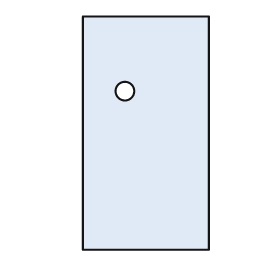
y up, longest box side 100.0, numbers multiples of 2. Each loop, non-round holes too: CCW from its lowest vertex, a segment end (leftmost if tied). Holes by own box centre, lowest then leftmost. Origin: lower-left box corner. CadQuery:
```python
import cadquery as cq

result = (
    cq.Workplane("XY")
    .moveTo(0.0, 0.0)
    .lineTo(54.0, 0.0)
    .lineTo(54.0, 100.0)
    .lineTo(0.0, 100.0)
    .close()
    .moveTo(18.0, 68.0)
    .circle(4.0)
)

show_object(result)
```